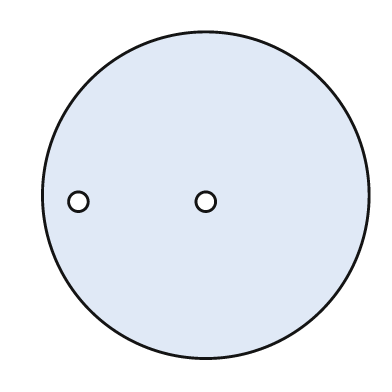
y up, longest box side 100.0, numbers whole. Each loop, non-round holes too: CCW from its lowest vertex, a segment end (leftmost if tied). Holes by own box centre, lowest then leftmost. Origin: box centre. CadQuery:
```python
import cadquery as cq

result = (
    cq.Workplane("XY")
    .moveTo(0.0, 0.0)
    .circle(50.0)
    .moveTo(-39.0, -2.0)
    .circle(3.0)
    .moveTo(0.0, -2.0)
    .circle(3.0)
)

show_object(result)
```